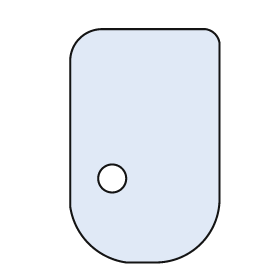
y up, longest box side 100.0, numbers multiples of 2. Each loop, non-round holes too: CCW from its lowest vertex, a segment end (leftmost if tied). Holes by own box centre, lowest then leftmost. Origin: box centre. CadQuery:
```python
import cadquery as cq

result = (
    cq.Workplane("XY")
    .moveTo(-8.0, -50.0)
    .lineTo(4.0, -50.0)
    .threePointArc((24.0, -42.0), (32.0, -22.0))
    .lineTo(32.0, 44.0)
    .threePointArc((30.0, 48.0), (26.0, 50.0))
    .lineTo(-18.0, 50.0)
    .threePointArc((-28.0, 46.0), (-32.0, 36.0))
    .lineTo(-32.0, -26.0)
    .threePointArc((-24.0, -42.0), (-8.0, -50.0))
    .close()
    .moveTo(-14.0, -14.0)
    .circle(6.0)
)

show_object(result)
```